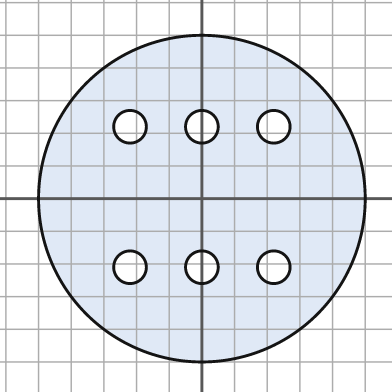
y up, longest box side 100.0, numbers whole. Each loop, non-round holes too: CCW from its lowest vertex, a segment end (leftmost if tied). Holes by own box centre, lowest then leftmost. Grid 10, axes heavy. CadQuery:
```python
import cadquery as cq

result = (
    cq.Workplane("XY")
    .moveTo(0.0, 0.0)
    .circle(50.0)
    .moveTo(-22.0, -21.0)
    .circle(5.0)
    .moveTo(0.0, -21.0)
    .circle(5.0)
    .moveTo(22.0, -21.0)
    .circle(5.0)
    .moveTo(-22.0, 22.0)
    .circle(5.0)
    .moveTo(0.0, 22.0)
    .circle(5.0)
    .moveTo(22.0, 22.0)
    .circle(5.0)
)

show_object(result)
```